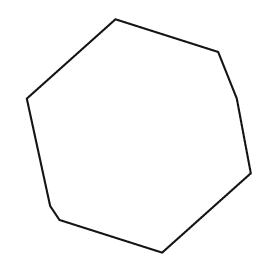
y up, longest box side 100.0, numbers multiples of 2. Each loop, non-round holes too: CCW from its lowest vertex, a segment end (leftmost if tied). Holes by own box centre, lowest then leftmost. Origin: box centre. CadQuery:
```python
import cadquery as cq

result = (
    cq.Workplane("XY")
    .moveTo(10.0, -50.0)
    .lineTo(48.0, -16.0)
    .lineTo(42.0, 16.0)
    .lineTo(34.0, 36.0)
    .lineTo(-10.0, 50.0)
    .lineTo(-48.0, 16.0)
    .lineTo(-38.0, -30.0)
    .lineTo(-34.0, -36.0)
    .close()
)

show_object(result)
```